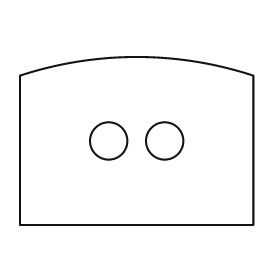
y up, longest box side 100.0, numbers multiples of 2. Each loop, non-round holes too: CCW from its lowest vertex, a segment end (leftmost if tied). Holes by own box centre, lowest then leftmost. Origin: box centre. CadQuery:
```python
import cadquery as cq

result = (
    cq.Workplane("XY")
    .moveTo(-50.0, -36.0)
    .lineTo(50.0, -36.0)
    .lineTo(50.0, 28.0)
    .threePointArc((0.0, 36.0), (-50.0, 28.0))
    .close()
    .moveTo(-12.0, 0.0)
    .circle(8.0)
    .moveTo(12.0, 0.0)
    .circle(8.0)
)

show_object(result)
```